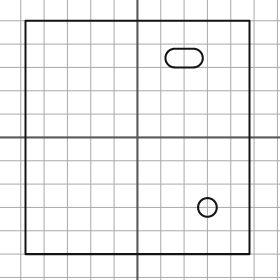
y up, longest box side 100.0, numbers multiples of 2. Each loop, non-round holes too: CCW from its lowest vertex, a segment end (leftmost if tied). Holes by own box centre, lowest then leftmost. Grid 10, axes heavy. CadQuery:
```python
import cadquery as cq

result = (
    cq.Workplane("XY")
    .moveTo(-48.0, -50.0)
    .lineTo(48.0, -50.0)
    .lineTo(48.0, 50.0)
    .lineTo(-48.0, 50.0)
    .close()
    .moveTo(30.0, -30.0)
    .circle(4.0)
    .moveTo(16.0, 30.0)
    .lineTo(24.0, 30.0)
    .threePointArc((28.0, 34.0), (24.0, 38.0))
    .lineTo(16.0, 38.0)
    .threePointArc((12.0, 34.0), (16.0, 30.0))
    .close()
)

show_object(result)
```